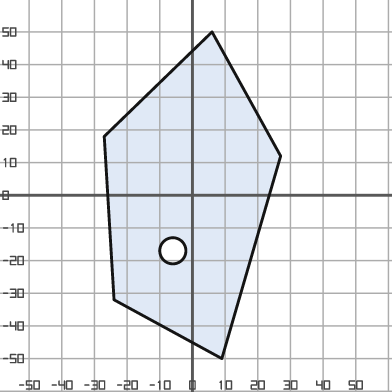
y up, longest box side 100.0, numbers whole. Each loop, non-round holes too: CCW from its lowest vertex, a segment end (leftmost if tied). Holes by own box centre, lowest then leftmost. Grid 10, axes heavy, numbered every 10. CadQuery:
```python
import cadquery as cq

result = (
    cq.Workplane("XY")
    .moveTo(9.0, -50.0)
    .lineTo(27.0, 12.0)
    .lineTo(6.0, 50.0)
    .lineTo(-27.0, 18.0)
    .lineTo(-24.0, -32.0)
    .close()
    .moveTo(-6.0, -17.0)
    .circle(4.0)
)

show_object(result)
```